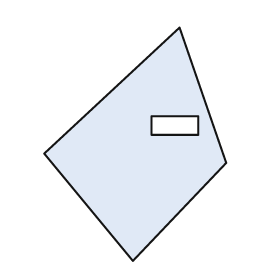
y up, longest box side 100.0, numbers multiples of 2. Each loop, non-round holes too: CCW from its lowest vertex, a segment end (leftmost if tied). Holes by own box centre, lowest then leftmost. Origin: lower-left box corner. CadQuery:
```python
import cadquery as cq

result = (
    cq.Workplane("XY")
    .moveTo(38.0, 0.0)
    .lineTo(78.0, 42.0)
    .lineTo(58.0, 100.0)
    .lineTo(0.0, 46.0)
    .close()
    .moveTo(46.0, 54.0)
    .lineTo(66.0, 54.0)
    .lineTo(66.0, 62.0)
    .lineTo(46.0, 62.0)
    .close()
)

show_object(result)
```